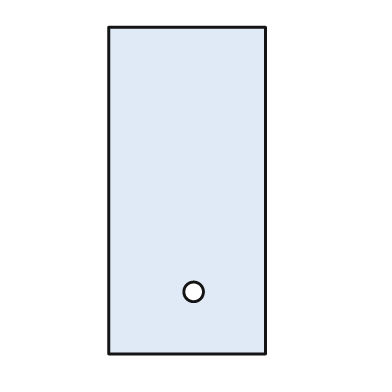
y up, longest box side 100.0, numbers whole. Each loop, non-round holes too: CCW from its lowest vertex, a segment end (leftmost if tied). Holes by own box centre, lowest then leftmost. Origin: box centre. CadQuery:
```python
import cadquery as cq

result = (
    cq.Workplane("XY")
    .moveTo(-24.0, -50.0)
    .lineTo(24.0, -50.0)
    .lineTo(24.0, 50.0)
    .lineTo(-24.0, 50.0)
    .close()
    .moveTo(2.0, -31.0)
    .circle(3.0)
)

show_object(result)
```